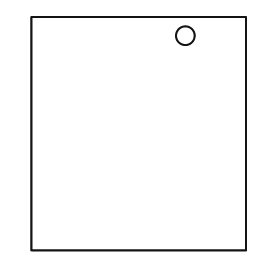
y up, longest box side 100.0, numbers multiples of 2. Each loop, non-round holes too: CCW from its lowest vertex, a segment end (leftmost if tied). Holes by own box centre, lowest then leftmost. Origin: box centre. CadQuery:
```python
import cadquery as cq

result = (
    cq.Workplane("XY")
    .moveTo(-46.0, -50.0)
    .lineTo(46.0, -50.0)
    .lineTo(46.0, 50.0)
    .lineTo(-46.0, 50.0)
    .close()
    .moveTo(20.0, 42.0)
    .circle(4.0)
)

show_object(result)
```